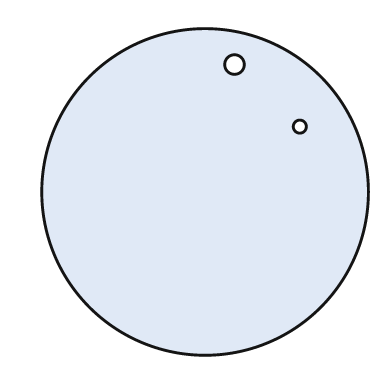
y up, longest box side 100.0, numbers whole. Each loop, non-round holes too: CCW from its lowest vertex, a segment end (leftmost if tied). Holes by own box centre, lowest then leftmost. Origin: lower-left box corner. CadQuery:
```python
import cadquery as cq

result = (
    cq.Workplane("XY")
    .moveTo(50.0, 50.0)
    .circle(50.0)
    .moveTo(79.0, 70.0)
    .circle(2.0)
    .moveTo(59.0, 89.0)
    .circle(3.0)
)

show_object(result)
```